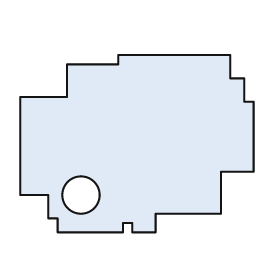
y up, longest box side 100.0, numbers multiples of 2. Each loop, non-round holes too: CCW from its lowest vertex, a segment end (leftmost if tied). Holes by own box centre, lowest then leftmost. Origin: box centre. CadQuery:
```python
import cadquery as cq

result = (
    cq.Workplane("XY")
    .moveTo(-34.0, -38.0)
    .lineTo(-6.0, -38.0)
    .lineTo(-6.0, -34.0)
    .lineTo(-2.0, -34.0)
    .lineTo(-2.0, -38.0)
    .lineTo(8.0, -38.0)
    .lineTo(8.0, -30.0)
    .lineTo(36.0, -30.0)
    .lineTo(36.0, -12.0)
    .lineTo(50.0, -12.0)
    .lineTo(50.0, 18.0)
    .lineTo(46.0, 18.0)
    .lineTo(46.0, 28.0)
    .lineTo(40.0, 28.0)
    .lineTo(40.0, 38.0)
    .lineTo(-8.0, 38.0)
    .lineTo(-8.0, 34.0)
    .lineTo(-30.0, 34.0)
    .lineTo(-30.0, 20.0)
    .lineTo(-50.0, 20.0)
    .lineTo(-50.0, -22.0)
    .lineTo(-38.0, -22.0)
    .lineTo(-38.0, -32.0)
    .lineTo(-34.0, -32.0)
    .close()
    .moveTo(-24.0, -22.0)
    .circle(8.0)
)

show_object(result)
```